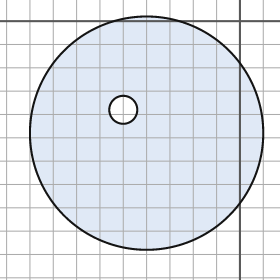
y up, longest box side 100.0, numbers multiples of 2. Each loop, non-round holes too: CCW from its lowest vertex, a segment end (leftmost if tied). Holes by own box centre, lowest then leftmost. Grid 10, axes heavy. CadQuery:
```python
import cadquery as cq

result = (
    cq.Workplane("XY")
    .moveTo(-40.0, -48.0)
    .circle(50.0)
    .moveTo(-50.0, -38.0)
    .circle(6.0)
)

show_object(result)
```